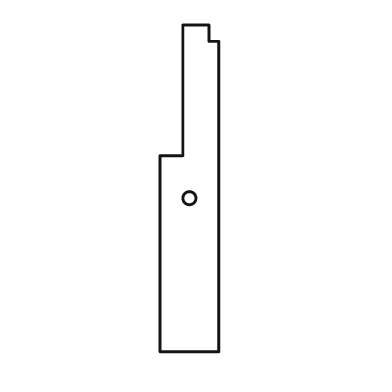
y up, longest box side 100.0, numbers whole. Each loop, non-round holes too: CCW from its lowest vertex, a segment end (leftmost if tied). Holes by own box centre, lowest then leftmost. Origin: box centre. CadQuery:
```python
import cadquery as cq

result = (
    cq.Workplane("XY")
    .moveTo(-9.0, -50.0)
    .lineTo(9.0, -50.0)
    .lineTo(9.0, 45.0)
    .lineTo(6.0, 45.0)
    .lineTo(6.0, 50.0)
    .lineTo(-2.0, 50.0)
    .lineTo(-2.0, 10.0)
    .lineTo(-9.0, 10.0)
    .close()
    .moveTo(0.0, -3.0)
    .circle(2.0)
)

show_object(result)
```